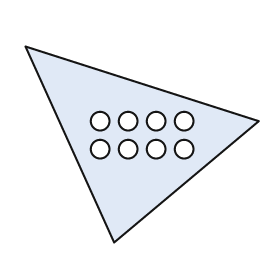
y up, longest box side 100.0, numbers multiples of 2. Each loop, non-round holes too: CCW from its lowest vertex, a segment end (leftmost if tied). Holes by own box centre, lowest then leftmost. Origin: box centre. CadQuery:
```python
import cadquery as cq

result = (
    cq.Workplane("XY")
    .moveTo(-12.0, -42.0)
    .lineTo(50.0, 10.0)
    .lineTo(-50.0, 42.0)
    .close()
    .moveTo(-18.0, -2.0)
    .circle(4.0)
    .moveTo(-6.0, -2.0)
    .circle(4.0)
    .moveTo(6.0, -2.0)
    .circle(4.0)
    .moveTo(18.0, -2.0)
    .circle(4.0)
    .moveTo(-18.0, 10.0)
    .circle(4.0)
    .moveTo(-6.0, 10.0)
    .circle(4.0)
    .moveTo(6.0, 10.0)
    .circle(4.0)
    .moveTo(18.0, 10.0)
    .circle(4.0)
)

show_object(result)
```